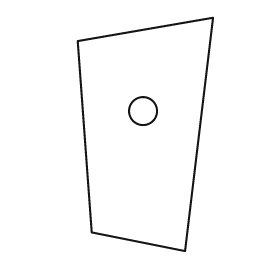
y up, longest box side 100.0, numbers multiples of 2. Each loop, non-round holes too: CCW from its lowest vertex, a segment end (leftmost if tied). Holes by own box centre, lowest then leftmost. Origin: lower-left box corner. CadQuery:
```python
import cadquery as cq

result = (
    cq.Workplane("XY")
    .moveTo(46.0, 0.0)
    .lineTo(58.0, 100.0)
    .lineTo(0.0, 90.0)
    .lineTo(6.0, 8.0)
    .close()
    .moveTo(28.0, 60.0)
    .circle(6.0)
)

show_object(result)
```